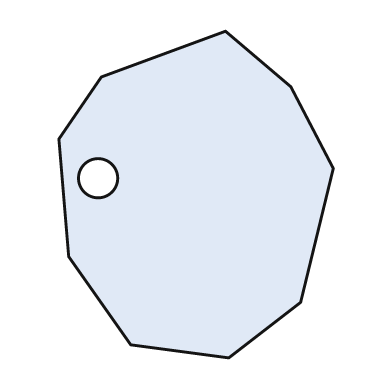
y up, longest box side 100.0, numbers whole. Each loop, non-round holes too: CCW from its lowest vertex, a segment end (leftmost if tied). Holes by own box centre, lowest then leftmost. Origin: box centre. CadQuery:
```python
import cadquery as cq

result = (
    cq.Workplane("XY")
    .moveTo(10.0, -50.0)
    .lineTo(32.0, -33.0)
    .lineTo(42.0, 8.0)
    .lineTo(29.0, 33.0)
    .lineTo(9.0, 50.0)
    .lineTo(-29.0, 36.0)
    .lineTo(-42.0, 17.0)
    .lineTo(-39.0, -19.0)
    .lineTo(-20.0, -46.0)
    .close()
    .moveTo(-30.0, 5.0)
    .circle(6.0)
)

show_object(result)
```